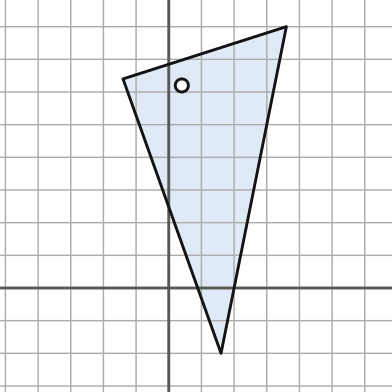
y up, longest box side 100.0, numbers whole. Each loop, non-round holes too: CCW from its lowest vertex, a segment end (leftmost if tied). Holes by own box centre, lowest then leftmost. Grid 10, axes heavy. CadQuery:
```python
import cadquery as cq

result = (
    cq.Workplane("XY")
    .moveTo(16.0, -20.0)
    .lineTo(36.0, 80.0)
    .lineTo(-14.0, 64.0)
    .close()
    .moveTo(4.0, 62.0)
    .circle(2.0)
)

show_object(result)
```